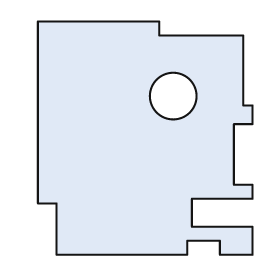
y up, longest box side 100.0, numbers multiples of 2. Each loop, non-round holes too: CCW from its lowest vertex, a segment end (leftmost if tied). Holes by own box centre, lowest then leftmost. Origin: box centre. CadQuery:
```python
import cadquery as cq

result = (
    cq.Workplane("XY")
    .moveTo(-38.0, -50.0)
    .lineTo(18.0, -50.0)
    .lineTo(18.0, -44.0)
    .lineTo(32.0, -44.0)
    .lineTo(32.0, -50.0)
    .lineTo(46.0, -50.0)
    .lineTo(46.0, -38.0)
    .lineTo(20.0, -38.0)
    .lineTo(20.0, -26.0)
    .lineTo(46.0, -26.0)
    .lineTo(46.0, -20.0)
    .lineTo(38.0, -20.0)
    .lineTo(38.0, 6.0)
    .lineTo(46.0, 6.0)
    .lineTo(46.0, 14.0)
    .lineTo(42.0, 14.0)
    .lineTo(42.0, 44.0)
    .lineTo(6.0, 44.0)
    .lineTo(6.0, 50.0)
    .lineTo(-46.0, 50.0)
    .lineTo(-46.0, -28.0)
    .lineTo(-38.0, -28.0)
    .close()
    .moveTo(12.0, 18.0)
    .circle(10.0)
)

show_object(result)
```